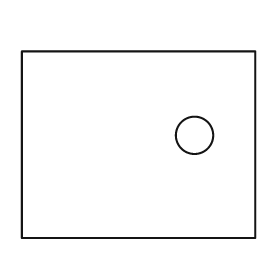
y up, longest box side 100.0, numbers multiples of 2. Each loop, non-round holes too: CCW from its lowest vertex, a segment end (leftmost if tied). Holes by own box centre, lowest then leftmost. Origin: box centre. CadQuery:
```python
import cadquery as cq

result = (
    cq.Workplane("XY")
    .moveTo(-50.0, -40.0)
    .lineTo(50.0, -40.0)
    .lineTo(50.0, 40.0)
    .lineTo(-50.0, 40.0)
    .close()
    .moveTo(24.0, 4.0)
    .circle(8.0)
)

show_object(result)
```